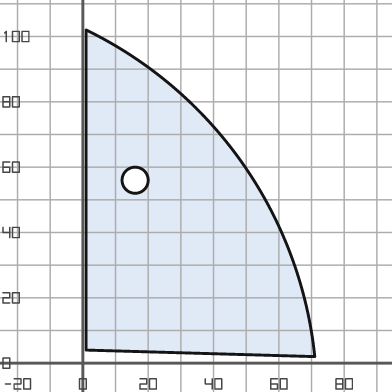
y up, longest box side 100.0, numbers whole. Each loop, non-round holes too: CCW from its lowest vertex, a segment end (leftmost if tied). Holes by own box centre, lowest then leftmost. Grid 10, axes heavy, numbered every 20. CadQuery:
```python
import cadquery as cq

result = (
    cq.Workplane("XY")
    .moveTo(71.0, 2.0)
    .threePointArc((49.0, 61.0), (1.0, 102.0))
    .lineTo(1.0, 4.0)
    .close()
    .moveTo(16.0, 56.0)
    .circle(4.0)
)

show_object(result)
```